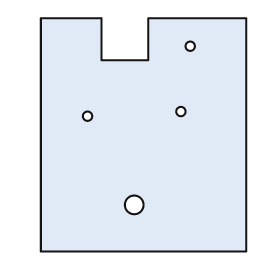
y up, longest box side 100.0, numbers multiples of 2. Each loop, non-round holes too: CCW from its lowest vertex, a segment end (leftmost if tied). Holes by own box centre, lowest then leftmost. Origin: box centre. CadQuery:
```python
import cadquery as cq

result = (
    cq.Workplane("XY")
    .moveTo(-44.0, -50.0)
    .lineTo(44.0, -50.0)
    .lineTo(44.0, 50.0)
    .lineTo(2.0, 50.0)
    .lineTo(2.0, 32.0)
    .lineTo(-18.0, 32.0)
    .lineTo(-18.0, 50.0)
    .lineTo(-44.0, 50.0)
    .close()
    .moveTo(-4.0, -30.0)
    .circle(4.0)
    .moveTo(-24.0, 8.0)
    .circle(2.0)
    .moveTo(16.0, 10.0)
    .circle(2.0)
    .moveTo(20.0, 38.0)
    .circle(2.0)
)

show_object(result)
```